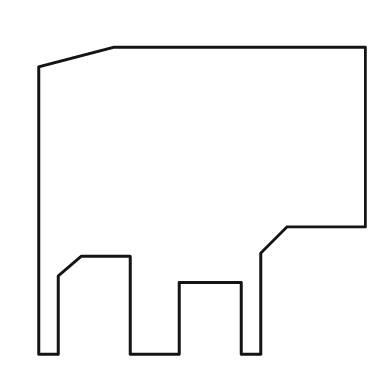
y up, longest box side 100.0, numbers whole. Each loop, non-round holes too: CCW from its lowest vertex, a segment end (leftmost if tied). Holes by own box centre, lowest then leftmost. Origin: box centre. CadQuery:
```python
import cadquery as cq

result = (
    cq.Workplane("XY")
    .moveTo(-50.0, -47.0)
    .lineTo(-44.0, -47.0)
    .lineTo(-44.0, -23.0)
    .lineTo(-37.0, -17.0)
    .lineTo(-22.0, -17.0)
    .lineTo(-22.0, -47.0)
    .lineTo(-7.0, -47.0)
    .lineTo(-7.0, -25.0)
    .lineTo(12.0, -25.0)
    .lineTo(12.0, -47.0)
    .lineTo(18.0, -47.0)
    .lineTo(18.0, -16.0)
    .lineTo(26.0, -8.0)
    .lineTo(50.0, -8.0)
    .lineTo(50.0, 47.0)
    .lineTo(-27.0, 47.0)
    .lineTo(-50.0, 41.0)
    .close()
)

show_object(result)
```